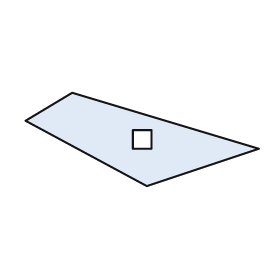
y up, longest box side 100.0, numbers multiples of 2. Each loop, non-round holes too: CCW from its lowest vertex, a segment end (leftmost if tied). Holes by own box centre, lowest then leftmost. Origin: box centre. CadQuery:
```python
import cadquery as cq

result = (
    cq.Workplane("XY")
    .moveTo(2.0, -20.0)
    .lineTo(50.0, -4.0)
    .lineTo(-30.0, 20.0)
    .lineTo(-50.0, 8.0)
    .close()
    .moveTo(-4.0, -4.0)
    .lineTo(4.0, -4.0)
    .lineTo(4.0, 4.0)
    .lineTo(-4.0, 4.0)
    .close()
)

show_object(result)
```